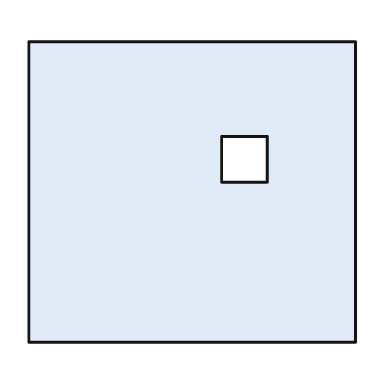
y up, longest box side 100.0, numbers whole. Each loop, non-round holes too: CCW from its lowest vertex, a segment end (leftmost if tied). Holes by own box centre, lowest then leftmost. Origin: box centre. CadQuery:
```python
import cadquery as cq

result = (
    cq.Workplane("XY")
    .moveTo(-50.0, -46.0)
    .lineTo(50.0, -46.0)
    .lineTo(50.0, 46.0)
    .lineTo(-50.0, 46.0)
    .close()
    .moveTo(9.0, 3.0)
    .lineTo(23.0, 3.0)
    .lineTo(23.0, 17.0)
    .lineTo(9.0, 17.0)
    .close()
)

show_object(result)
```